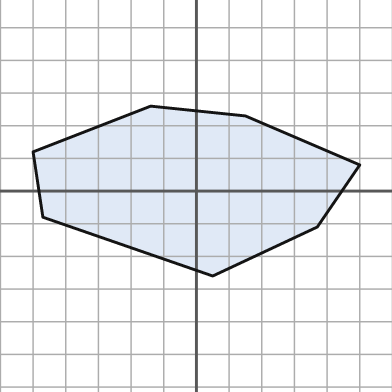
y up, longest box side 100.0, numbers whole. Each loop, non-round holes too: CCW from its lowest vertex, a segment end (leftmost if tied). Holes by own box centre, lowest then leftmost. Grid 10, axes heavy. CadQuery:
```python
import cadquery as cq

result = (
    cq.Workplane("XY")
    .moveTo(5.0, -26.0)
    .lineTo(37.0, -11.0)
    .lineTo(50.0, 8.0)
    .lineTo(15.0, 23.0)
    .lineTo(-14.0, 26.0)
    .lineTo(-50.0, 12.0)
    .lineTo(-47.0, -8.0)
    .close()
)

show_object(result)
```